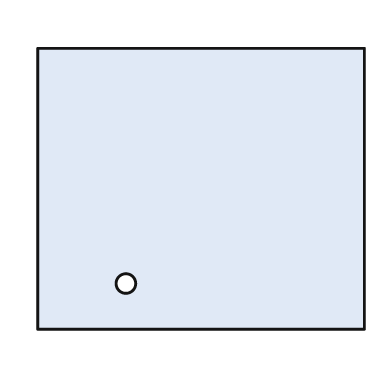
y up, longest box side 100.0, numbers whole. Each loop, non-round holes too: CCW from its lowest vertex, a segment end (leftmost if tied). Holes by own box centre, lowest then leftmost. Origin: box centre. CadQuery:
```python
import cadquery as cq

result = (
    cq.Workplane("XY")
    .moveTo(-50.0, -43.0)
    .lineTo(50.0, -43.0)
    .lineTo(50.0, 43.0)
    .lineTo(-50.0, 43.0)
    .close()
    .moveTo(-23.0, -29.0)
    .circle(3.0)
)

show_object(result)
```